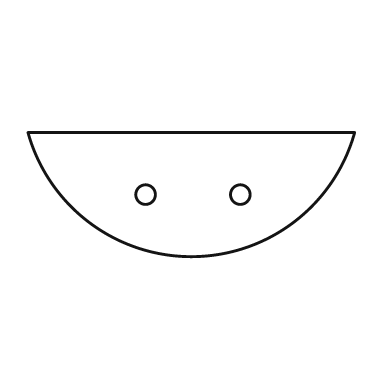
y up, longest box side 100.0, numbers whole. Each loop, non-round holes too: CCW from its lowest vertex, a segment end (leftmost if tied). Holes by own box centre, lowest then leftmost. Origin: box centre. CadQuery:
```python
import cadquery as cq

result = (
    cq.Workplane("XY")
    .moveTo(-50.0, 19.0)
    .threePointArc((0.0, -19.0), (50.0, 19.0))
    .close()
    .moveTo(-14.0, 0.0)
    .circle(3.0)
    .moveTo(15.0, 0.0)
    .circle(3.0)
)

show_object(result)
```